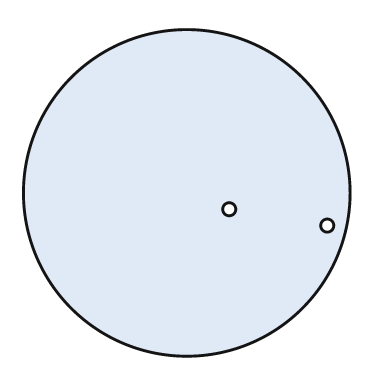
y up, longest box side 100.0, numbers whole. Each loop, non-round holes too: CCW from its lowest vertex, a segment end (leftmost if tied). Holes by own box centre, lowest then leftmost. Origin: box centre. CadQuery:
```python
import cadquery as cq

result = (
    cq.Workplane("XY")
    .moveTo(0.0, 0.0)
    .circle(50.0)
    .moveTo(43.0, -10.0)
    .circle(2.0)
    .moveTo(13.0, -5.0)
    .circle(2.0)
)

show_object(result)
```